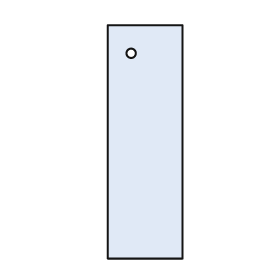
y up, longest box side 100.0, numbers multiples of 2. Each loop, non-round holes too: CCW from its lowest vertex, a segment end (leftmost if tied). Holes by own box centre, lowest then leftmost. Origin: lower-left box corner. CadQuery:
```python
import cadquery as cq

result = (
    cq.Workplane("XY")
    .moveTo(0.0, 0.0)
    .lineTo(32.0, 0.0)
    .lineTo(32.0, 100.0)
    .lineTo(0.0, 100.0)
    .close()
    .moveTo(10.0, 88.0)
    .circle(2.0)
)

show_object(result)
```